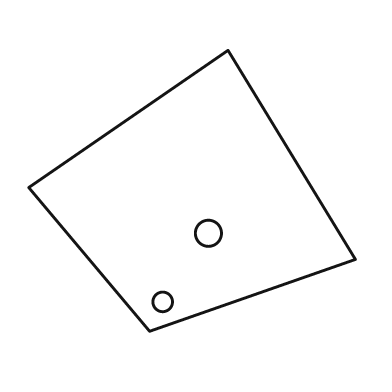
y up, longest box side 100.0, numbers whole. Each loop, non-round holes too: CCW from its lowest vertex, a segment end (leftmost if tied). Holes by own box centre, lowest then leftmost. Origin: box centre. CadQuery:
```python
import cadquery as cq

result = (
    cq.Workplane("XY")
    .moveTo(-13.0, -43.0)
    .lineTo(50.0, -21.0)
    .lineTo(11.0, 43.0)
    .lineTo(-50.0, 1.0)
    .close()
    .moveTo(-9.0, -34.0)
    .circle(3.0)
    .moveTo(5.0, -13.0)
    .circle(4.0)
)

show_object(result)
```